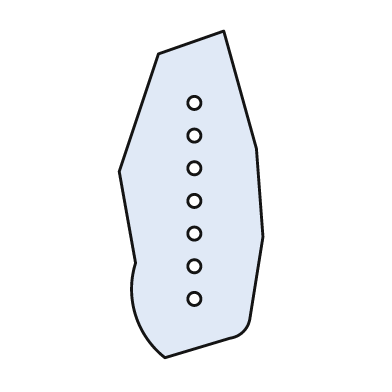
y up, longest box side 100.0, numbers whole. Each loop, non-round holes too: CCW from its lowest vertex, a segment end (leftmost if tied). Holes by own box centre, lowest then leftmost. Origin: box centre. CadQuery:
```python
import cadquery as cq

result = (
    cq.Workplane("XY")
    .moveTo(-8.0, -50.0)
    .lineTo(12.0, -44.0)
    .threePointArc((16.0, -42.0), (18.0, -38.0))
    .lineTo(22.0, -13.0)
    .lineTo(20.0, 14.0)
    .lineTo(10.0, 50.0)
    .lineTo(-10.0, 43.0)
    .lineTo(-22.0, 7.0)
    .lineTo(-17.0, -21.0)
    .threePointArc((-17.0, -37.0), (-8.0, -50.0))
    .close()
    .moveTo(1.0, -32.0)
    .circle(2.0)
    .moveTo(1.0, -22.0)
    .circle(2.0)
    .moveTo(1.0, -12.0)
    .circle(2.0)
    .moveTo(1.0, -2.0)
    .circle(2.0)
    .moveTo(1.0, 8.0)
    .circle(2.0)
    .moveTo(1.0, 18.0)
    .circle(2.0)
    .moveTo(1.0, 28.0)
    .circle(2.0)
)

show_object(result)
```